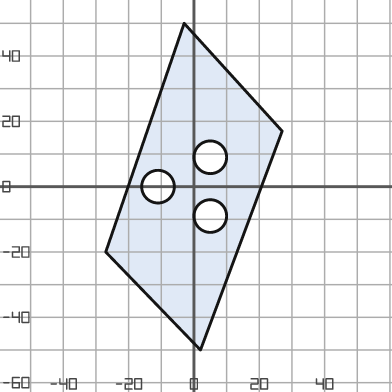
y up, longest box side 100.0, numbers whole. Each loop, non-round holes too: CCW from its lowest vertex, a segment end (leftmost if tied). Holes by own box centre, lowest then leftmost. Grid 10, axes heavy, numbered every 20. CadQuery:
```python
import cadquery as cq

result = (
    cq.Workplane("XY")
    .moveTo(2.0, -50.0)
    .lineTo(27.0, 17.0)
    .lineTo(-3.0, 50.0)
    .lineTo(-27.0, -20.0)
    .close()
    .moveTo(5.0, -9.0)
    .circle(5.0)
    .moveTo(-11.0, 0.0)
    .circle(5.0)
    .moveTo(5.0, 9.0)
    .circle(5.0)
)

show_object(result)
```